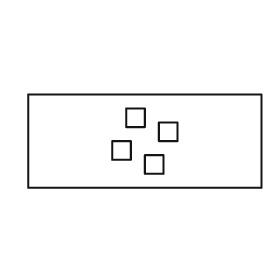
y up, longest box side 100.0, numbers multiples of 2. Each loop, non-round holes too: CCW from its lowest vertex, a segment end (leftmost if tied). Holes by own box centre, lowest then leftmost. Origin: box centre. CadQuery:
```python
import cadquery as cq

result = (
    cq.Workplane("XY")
    .moveTo(-50.0, -20.0)
    .lineTo(50.0, -20.0)
    .lineTo(50.0, 20.0)
    .lineTo(-50.0, 20.0)
    .close()
    .moveTo(0.0, -14.0)
    .lineTo(8.0, -14.0)
    .lineTo(8.0, -6.0)
    .lineTo(0.0, -6.0)
    .close()
    .moveTo(-14.0, -8.0)
    .lineTo(-6.0, -8.0)
    .lineTo(-6.0, 0.0)
    .lineTo(-14.0, 0.0)
    .close()
    .moveTo(6.0, 0.0)
    .lineTo(14.0, 0.0)
    .lineTo(14.0, 8.0)
    .lineTo(6.0, 8.0)
    .close()
    .moveTo(-8.0, 6.0)
    .lineTo(0.0, 6.0)
    .lineTo(0.0, 14.0)
    .lineTo(-8.0, 14.0)
    .close()
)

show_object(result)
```